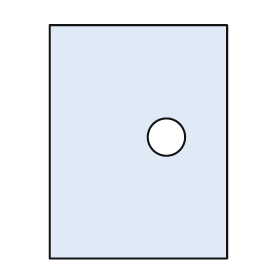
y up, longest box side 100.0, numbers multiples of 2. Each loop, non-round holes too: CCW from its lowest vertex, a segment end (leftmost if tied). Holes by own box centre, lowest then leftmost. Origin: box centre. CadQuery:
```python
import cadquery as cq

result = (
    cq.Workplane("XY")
    .moveTo(-38.0, -50.0)
    .lineTo(38.0, -50.0)
    .lineTo(38.0, 50.0)
    .lineTo(-38.0, 50.0)
    .close()
    .moveTo(12.0, 2.0)
    .circle(8.0)
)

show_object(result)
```